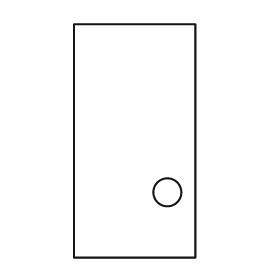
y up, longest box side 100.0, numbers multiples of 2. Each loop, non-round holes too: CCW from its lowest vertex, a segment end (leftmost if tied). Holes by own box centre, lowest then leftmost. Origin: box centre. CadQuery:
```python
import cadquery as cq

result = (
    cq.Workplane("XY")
    .moveTo(-26.0, -50.0)
    .lineTo(26.0, -50.0)
    .lineTo(26.0, 50.0)
    .lineTo(-26.0, 50.0)
    .close()
    .moveTo(14.0, -22.0)
    .circle(6.0)
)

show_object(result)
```